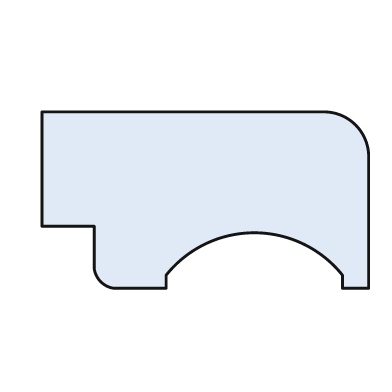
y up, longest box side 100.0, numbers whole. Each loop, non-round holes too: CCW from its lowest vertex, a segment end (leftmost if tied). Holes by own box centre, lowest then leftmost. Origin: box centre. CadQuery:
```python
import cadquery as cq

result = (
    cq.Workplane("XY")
    .moveTo(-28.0, -27.0)
    .lineTo(-12.0, -27.0)
    .lineTo(-12.0, -23.0)
    .threePointArc((15.0, -10.0), (42.0, -23.0))
    .lineTo(42.0, -27.0)
    .lineTo(50.0, -27.0)
    .lineTo(50.0, 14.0)
    .threePointArc((46.0, 23.0), (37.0, 27.0))
    .lineTo(-50.0, 27.0)
    .lineTo(-50.0, -8.0)
    .lineTo(-34.0, -8.0)
    .lineTo(-34.0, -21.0)
    .threePointArc((-32.0, -25.0), (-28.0, -27.0))
    .close()
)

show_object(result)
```